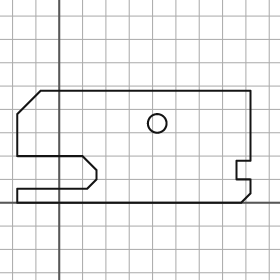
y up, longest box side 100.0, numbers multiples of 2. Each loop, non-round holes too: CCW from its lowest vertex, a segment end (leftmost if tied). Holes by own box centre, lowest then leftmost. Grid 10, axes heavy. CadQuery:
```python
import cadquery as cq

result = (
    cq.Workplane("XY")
    .moveTo(-18.0, 0.0)
    .lineTo(78.0, 0.0)
    .lineTo(82.0, 4.0)
    .lineTo(82.0, 10.0)
    .lineTo(76.0, 10.0)
    .lineTo(76.0, 18.0)
    .lineTo(82.0, 18.0)
    .lineTo(82.0, 48.0)
    .lineTo(-8.0, 48.0)
    .lineTo(-18.0, 38.0)
    .lineTo(-18.0, 20.0)
    .lineTo(10.0, 20.0)
    .lineTo(16.0, 14.0)
    .lineTo(16.0, 10.0)
    .lineTo(12.0, 6.0)
    .lineTo(-18.0, 6.0)
    .close()
    .moveTo(42.0, 34.0)
    .circle(4.0)
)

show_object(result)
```